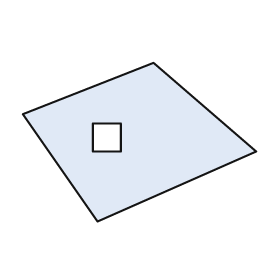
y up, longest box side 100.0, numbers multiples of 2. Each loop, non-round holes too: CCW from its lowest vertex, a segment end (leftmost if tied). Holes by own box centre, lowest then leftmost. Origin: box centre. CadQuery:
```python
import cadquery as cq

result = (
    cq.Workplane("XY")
    .moveTo(-18.0, -34.0)
    .lineTo(50.0, -4.0)
    .lineTo(6.0, 34.0)
    .lineTo(-50.0, 12.0)
    .close()
    .moveTo(-20.0, -4.0)
    .lineTo(-8.0, -4.0)
    .lineTo(-8.0, 8.0)
    .lineTo(-20.0, 8.0)
    .close()
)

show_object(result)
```